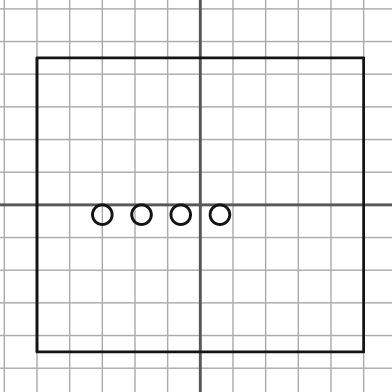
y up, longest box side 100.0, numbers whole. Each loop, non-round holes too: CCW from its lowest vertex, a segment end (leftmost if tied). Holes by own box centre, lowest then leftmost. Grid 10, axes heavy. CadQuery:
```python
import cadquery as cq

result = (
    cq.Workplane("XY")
    .moveTo(-50.0, -45.0)
    .lineTo(50.0, -45.0)
    .lineTo(50.0, 45.0)
    .lineTo(-50.0, 45.0)
    .close()
    .moveTo(-30.0, -3.0)
    .circle(3.0)
    .moveTo(-18.0, -3.0)
    .circle(3.0)
    .moveTo(-6.0, -3.0)
    .circle(3.0)
    .moveTo(6.0, -3.0)
    .circle(3.0)
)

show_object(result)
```